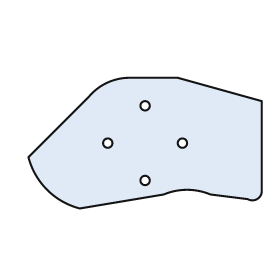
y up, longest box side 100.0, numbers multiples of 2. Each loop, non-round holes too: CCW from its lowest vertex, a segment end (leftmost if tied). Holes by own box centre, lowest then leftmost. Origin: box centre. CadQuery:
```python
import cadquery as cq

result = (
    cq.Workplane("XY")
    .moveTo(-28.0, -28.0)
    .lineTo(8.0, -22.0)
    .threePointArc((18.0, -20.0), (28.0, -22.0))
    .lineTo(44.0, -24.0)
    .threePointArc((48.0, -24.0), (50.0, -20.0))
    .lineTo(50.0, 18.0)
    .lineTo(14.0, 28.0)
    .lineTo(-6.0, 28.0)
    .threePointArc((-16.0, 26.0), (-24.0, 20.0))
    .lineTo(-50.0, -6.0)
    .threePointArc((-42.0, -20.0), (-28.0, -28.0))
    .close()
    .moveTo(0.0, -16.0)
    .circle(2.0)
    .moveTo(-16.0, 0.0)
    .circle(2.0)
    .moveTo(16.0, 0.0)
    .circle(2.0)
    .moveTo(0.0, 16.0)
    .circle(2.0)
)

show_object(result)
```